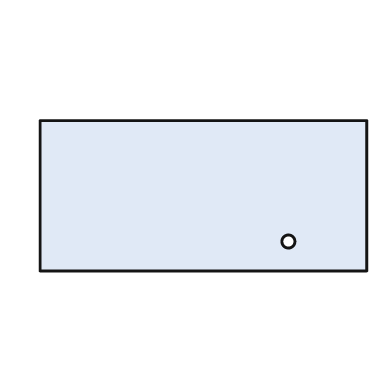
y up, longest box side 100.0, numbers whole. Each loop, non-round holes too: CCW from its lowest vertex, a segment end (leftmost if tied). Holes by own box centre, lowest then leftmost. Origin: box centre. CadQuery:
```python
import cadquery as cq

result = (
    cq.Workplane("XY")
    .moveTo(-50.0, -23.0)
    .lineTo(50.0, -23.0)
    .lineTo(50.0, 23.0)
    .lineTo(-50.0, 23.0)
    .close()
    .moveTo(26.0, -14.0)
    .circle(2.0)
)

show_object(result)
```